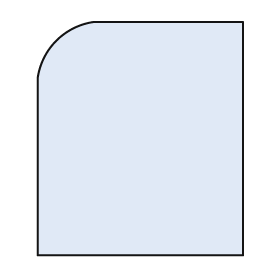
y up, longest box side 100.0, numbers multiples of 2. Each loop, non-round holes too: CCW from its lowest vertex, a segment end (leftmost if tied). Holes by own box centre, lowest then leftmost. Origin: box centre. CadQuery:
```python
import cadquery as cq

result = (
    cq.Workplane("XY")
    .moveTo(-44.0, -50.0)
    .lineTo(44.0, -50.0)
    .lineTo(44.0, 50.0)
    .lineTo(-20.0, 50.0)
    .threePointArc((-36.0, 42.0), (-44.0, 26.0))
    .close()
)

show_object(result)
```